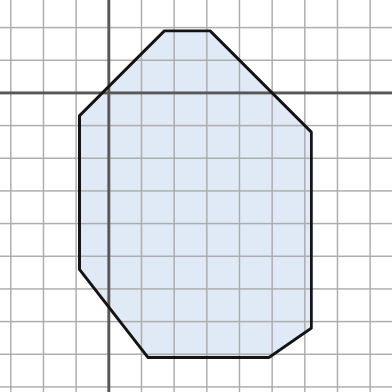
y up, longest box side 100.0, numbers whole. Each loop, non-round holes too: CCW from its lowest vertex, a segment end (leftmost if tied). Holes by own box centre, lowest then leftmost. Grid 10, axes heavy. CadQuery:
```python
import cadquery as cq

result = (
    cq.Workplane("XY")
    .moveTo(12.0, -81.0)
    .lineTo(49.0, -81.0)
    .lineTo(62.0, -72.0)
    .lineTo(62.0, -12.0)
    .lineTo(31.0, 19.0)
    .lineTo(17.0, 19.0)
    .lineTo(-9.0, -7.0)
    .lineTo(-9.0, -54.0)
    .close()
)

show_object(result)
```